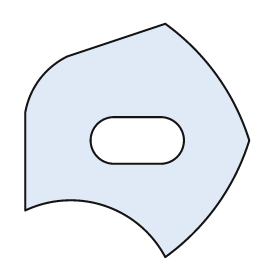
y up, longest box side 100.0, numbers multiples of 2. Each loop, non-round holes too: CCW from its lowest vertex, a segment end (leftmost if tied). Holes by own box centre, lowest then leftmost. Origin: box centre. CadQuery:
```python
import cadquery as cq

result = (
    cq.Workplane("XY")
    .moveTo(12.0, -50.0)
    .threePointArc((34.0, -28.0), (48.0, 0.0))
    .threePointArc((34.0, 28.0), (12.0, 50.0))
    .lineTo(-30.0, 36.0)
    .threePointArc((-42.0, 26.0), (-48.0, 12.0))
    .lineTo(-48.0, -30.0)
    .threePointArc((-14.0, -28.0), (12.0, -50.0))
    .close()
    .moveTo(-10.0, -10.0)
    .lineTo(10.0, -10.0)
    .threePointArc((20.0, 0.0), (10.0, 10.0))
    .lineTo(-10.0, 10.0)
    .threePointArc((-20.0, 0.0), (-10.0, -10.0))
    .close()
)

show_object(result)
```